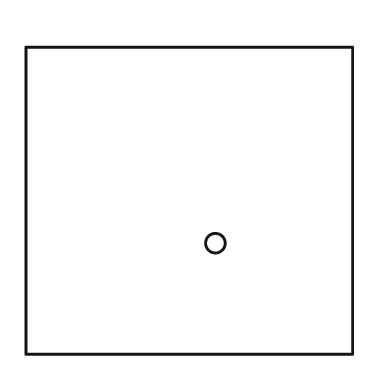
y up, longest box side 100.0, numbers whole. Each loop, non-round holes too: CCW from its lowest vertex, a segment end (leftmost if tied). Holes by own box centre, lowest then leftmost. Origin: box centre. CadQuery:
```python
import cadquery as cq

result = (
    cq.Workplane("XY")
    .moveTo(-50.0, -47.0)
    .lineTo(50.0, -47.0)
    .lineTo(50.0, 47.0)
    .lineTo(-50.0, 47.0)
    .close()
    .moveTo(8.0, -13.0)
    .circle(3.0)
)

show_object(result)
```